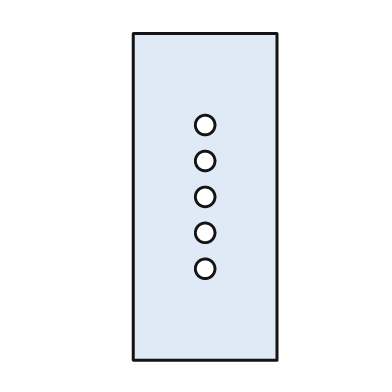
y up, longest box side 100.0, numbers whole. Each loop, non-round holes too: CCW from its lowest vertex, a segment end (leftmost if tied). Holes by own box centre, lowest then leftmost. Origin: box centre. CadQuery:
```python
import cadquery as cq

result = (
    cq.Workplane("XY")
    .moveTo(-22.0, -50.0)
    .lineTo(22.0, -50.0)
    .lineTo(22.0, 50.0)
    .lineTo(-22.0, 50.0)
    .close()
    .moveTo(0.0, -22.0)
    .circle(3.0)
    .moveTo(0.0, -11.0)
    .circle(3.0)
    .moveTo(0.0, 0.0)
    .circle(3.0)
    .moveTo(0.0, 11.0)
    .circle(3.0)
    .moveTo(0.0, 22.0)
    .circle(3.0)
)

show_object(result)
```